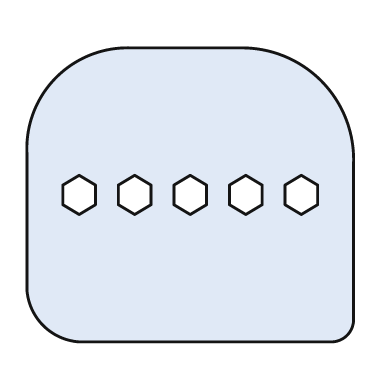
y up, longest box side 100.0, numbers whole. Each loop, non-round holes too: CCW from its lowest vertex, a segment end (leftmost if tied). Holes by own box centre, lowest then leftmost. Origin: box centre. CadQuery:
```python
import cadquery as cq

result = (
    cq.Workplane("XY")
    .moveTo(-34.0, -45.0)
    .lineTo(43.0, -45.0)
    .threePointArc((48.0, -43.0), (50.0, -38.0))
    .lineTo(50.0, 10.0)
    .threePointArc((40.0, 35.0), (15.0, 45.0))
    .lineTo(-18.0, 45.0)
    .threePointArc((-41.0, 36.0), (-50.0, 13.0))
    .lineTo(-50.0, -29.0)
    .threePointArc((-45.0, -40.0), (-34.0, -45.0))
    .close()
    .moveTo(-34.0, -6.0)
    .lineTo(-29.0, -3.0)
    .lineTo(-29.0, 3.0)
    .lineTo(-34.0, 6.0)
    .lineTo(-39.0, 3.0)
    .lineTo(-39.0, -3.0)
    .close()
    .moveTo(-17.0, -6.0)
    .lineTo(-12.0, -3.0)
    .lineTo(-12.0, 3.0)
    .lineTo(-17.0, 6.0)
    .lineTo(-22.0, 3.0)
    .lineTo(-22.0, -3.0)
    .close()
    .moveTo(0.0, -6.0)
    .lineTo(5.0, -3.0)
    .lineTo(5.0, 3.0)
    .lineTo(0.0, 6.0)
    .lineTo(-5.0, 3.0)
    .lineTo(-5.0, -3.0)
    .close()
    .moveTo(17.0, -6.0)
    .lineTo(22.0, -3.0)
    .lineTo(22.0, 3.0)
    .lineTo(17.0, 6.0)
    .lineTo(12.0, 3.0)
    .lineTo(12.0, -3.0)
    .close()
    .moveTo(34.0, -6.0)
    .lineTo(39.0, -3.0)
    .lineTo(39.0, 3.0)
    .lineTo(34.0, 6.0)
    .lineTo(29.0, 3.0)
    .lineTo(29.0, -3.0)
    .close()
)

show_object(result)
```